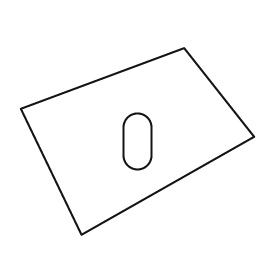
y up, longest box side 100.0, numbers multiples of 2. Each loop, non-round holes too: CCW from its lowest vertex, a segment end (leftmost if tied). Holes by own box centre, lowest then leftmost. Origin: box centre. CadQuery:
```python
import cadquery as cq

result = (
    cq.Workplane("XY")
    .moveTo(-24.0, -40.0)
    .lineTo(50.0, 2.0)
    .lineTo(20.0, 40.0)
    .lineTo(-50.0, 14.0)
    .close()
    .moveTo(-6.0, -6.0)
    .threePointArc((0.0, -12.0), (6.0, -6.0))
    .lineTo(6.0, 6.0)
    .threePointArc((0.0, 12.0), (-6.0, 6.0))
    .close()
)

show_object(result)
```